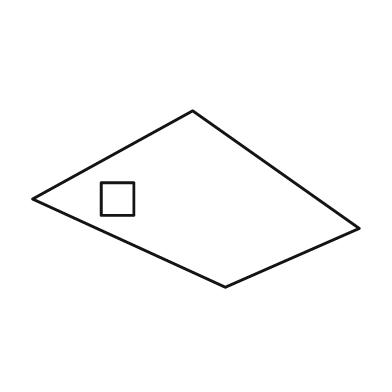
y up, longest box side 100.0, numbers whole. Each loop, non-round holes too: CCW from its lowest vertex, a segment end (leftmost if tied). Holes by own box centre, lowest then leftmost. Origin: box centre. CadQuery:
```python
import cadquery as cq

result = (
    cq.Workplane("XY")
    .moveTo(9.0, -27.0)
    .lineTo(50.0, -9.0)
    .lineTo(-1.0, 27.0)
    .lineTo(-50.0, 0.0)
    .close()
    .moveTo(-29.0, -5.0)
    .lineTo(-19.0, -5.0)
    .lineTo(-19.0, 5.0)
    .lineTo(-29.0, 5.0)
    .close()
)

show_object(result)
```